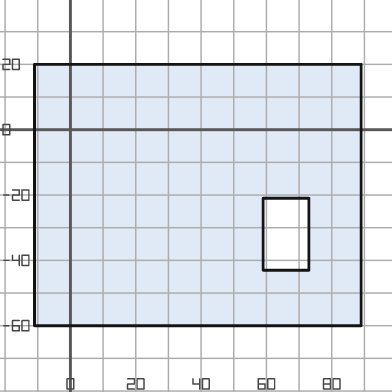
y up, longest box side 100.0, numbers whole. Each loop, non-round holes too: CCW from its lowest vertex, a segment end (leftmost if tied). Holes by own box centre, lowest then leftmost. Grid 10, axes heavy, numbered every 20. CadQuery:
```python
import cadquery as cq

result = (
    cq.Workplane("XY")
    .moveTo(-11.0, -60.0)
    .lineTo(89.0, -60.0)
    .lineTo(89.0, 20.0)
    .lineTo(-11.0, 20.0)
    .close()
    .moveTo(59.0, -43.0)
    .lineTo(73.0, -43.0)
    .lineTo(73.0, -21.0)
    .lineTo(59.0, -21.0)
    .close()
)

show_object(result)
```